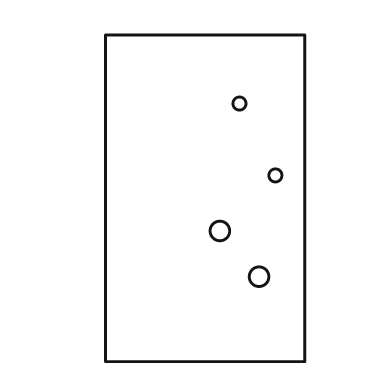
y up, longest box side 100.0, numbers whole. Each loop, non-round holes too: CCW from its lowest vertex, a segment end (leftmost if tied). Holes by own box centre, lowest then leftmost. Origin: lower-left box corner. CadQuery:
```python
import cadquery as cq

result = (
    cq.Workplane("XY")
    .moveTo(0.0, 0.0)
    .lineTo(61.0, 0.0)
    .lineTo(61.0, 100.0)
    .lineTo(0.0, 100.0)
    .close()
    .moveTo(47.0, 26.0)
    .circle(3.0)
    .moveTo(35.0, 40.0)
    .circle(3.0)
    .moveTo(52.0, 57.0)
    .circle(2.0)
    .moveTo(41.0, 79.0)
    .circle(2.0)
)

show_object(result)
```